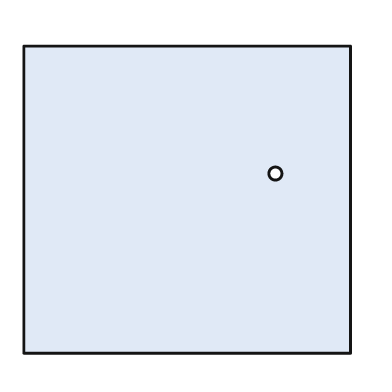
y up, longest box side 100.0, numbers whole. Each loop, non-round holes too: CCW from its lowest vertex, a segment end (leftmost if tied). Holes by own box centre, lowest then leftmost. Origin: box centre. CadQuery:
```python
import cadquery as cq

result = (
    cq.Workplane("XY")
    .moveTo(-50.0, -47.0)
    .lineTo(50.0, -47.0)
    .lineTo(50.0, 47.0)
    .lineTo(-50.0, 47.0)
    .close()
    .moveTo(27.0, 8.0)
    .circle(2.0)
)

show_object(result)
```